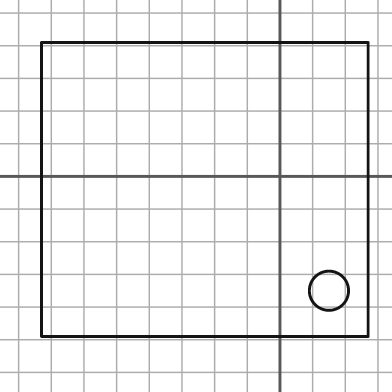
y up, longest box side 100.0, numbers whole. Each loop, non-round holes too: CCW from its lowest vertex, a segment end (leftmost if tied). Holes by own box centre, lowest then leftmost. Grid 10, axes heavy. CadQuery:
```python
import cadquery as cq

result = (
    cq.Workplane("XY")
    .moveTo(-73.0, -49.0)
    .lineTo(27.0, -49.0)
    .lineTo(27.0, 41.0)
    .lineTo(-73.0, 41.0)
    .close()
    .moveTo(15.0, -35.0)
    .circle(6.0)
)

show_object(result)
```